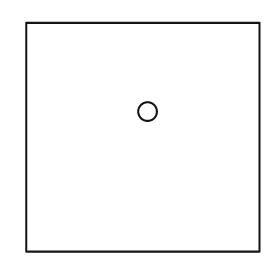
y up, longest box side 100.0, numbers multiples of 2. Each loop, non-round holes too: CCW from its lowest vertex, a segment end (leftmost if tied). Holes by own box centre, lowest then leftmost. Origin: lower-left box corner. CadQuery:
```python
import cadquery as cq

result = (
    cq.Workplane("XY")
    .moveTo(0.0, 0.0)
    .lineTo(100.0, 0.0)
    .lineTo(100.0, 98.0)
    .lineTo(0.0, 98.0)
    .close()
    .moveTo(52.0, 60.0)
    .circle(4.0)
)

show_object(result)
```